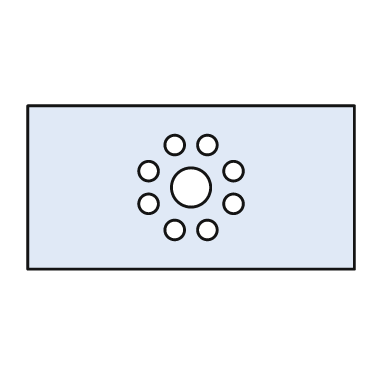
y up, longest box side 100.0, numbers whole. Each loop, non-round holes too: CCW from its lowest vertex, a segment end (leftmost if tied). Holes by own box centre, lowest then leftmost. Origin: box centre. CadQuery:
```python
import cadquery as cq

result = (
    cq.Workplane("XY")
    .moveTo(-50.0, -25.0)
    .lineTo(50.0, -25.0)
    .lineTo(50.0, 25.0)
    .lineTo(-50.0, 25.0)
    .close()
    .moveTo(-5.0, -13.0)
    .circle(3.0)
    .moveTo(5.0, -13.0)
    .circle(3.0)
    .moveTo(-13.0, -5.0)
    .circle(3.0)
    .moveTo(13.0, -5.0)
    .circle(3.0)
    .moveTo(0.0, 0.0)
    .circle(6.0)
    .moveTo(-13.0, 5.0)
    .circle(3.0)
    .moveTo(13.0, 5.0)
    .circle(3.0)
    .moveTo(-5.0, 13.0)
    .circle(3.0)
    .moveTo(5.0, 13.0)
    .circle(3.0)
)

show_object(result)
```